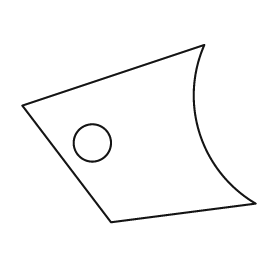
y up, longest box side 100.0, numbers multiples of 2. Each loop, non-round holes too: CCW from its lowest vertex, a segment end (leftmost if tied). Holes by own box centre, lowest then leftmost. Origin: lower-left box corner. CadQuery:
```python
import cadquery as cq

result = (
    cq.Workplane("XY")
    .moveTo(38.0, 0.0)
    .lineTo(100.0, 8.0)
    .threePointArc((76.0, 38.0), (78.0, 76.0))
    .lineTo(0.0, 50.0)
    .close()
    .moveTo(30.0, 34.0)
    .circle(8.0)
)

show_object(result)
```